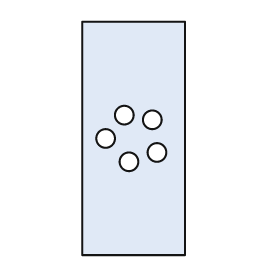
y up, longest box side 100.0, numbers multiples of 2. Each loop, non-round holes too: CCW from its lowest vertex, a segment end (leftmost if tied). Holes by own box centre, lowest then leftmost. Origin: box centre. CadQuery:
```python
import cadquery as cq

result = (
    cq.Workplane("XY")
    .moveTo(-22.0, -50.0)
    .lineTo(22.0, -50.0)
    .lineTo(22.0, 50.0)
    .lineTo(-22.0, 50.0)
    .close()
    .moveTo(-2.0, -10.0)
    .circle(4.0)
    .moveTo(10.0, -6.0)
    .circle(4.0)
    .moveTo(-12.0, 0.0)
    .circle(4.0)
    .moveTo(8.0, 8.0)
    .circle(4.0)
    .moveTo(-4.0, 10.0)
    .circle(4.0)
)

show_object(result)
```